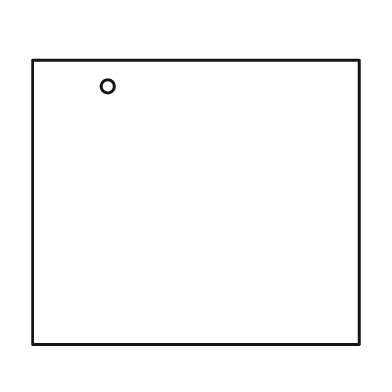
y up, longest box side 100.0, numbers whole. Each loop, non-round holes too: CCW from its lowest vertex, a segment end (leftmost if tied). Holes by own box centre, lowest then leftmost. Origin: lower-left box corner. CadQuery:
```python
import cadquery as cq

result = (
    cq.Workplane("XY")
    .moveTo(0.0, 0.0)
    .lineTo(100.0, 0.0)
    .lineTo(100.0, 87.0)
    .lineTo(0.0, 87.0)
    .close()
    .moveTo(23.0, 79.0)
    .circle(2.0)
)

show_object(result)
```